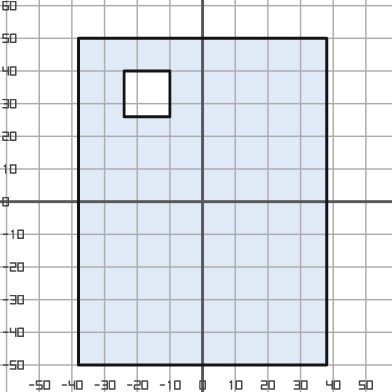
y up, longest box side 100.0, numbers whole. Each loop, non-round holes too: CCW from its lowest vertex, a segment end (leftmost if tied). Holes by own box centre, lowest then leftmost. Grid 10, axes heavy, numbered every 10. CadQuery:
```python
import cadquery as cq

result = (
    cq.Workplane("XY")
    .moveTo(-38.0, -50.0)
    .lineTo(38.0, -50.0)
    .lineTo(38.0, 50.0)
    .lineTo(-38.0, 50.0)
    .close()
    .moveTo(-24.0, 26.0)
    .lineTo(-10.0, 26.0)
    .lineTo(-10.0, 40.0)
    .lineTo(-24.0, 40.0)
    .close()
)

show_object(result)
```